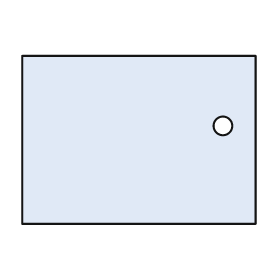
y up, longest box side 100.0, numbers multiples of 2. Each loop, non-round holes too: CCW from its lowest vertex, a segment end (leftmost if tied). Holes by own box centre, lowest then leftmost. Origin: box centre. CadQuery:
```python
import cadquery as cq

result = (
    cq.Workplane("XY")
    .moveTo(-50.0, -36.0)
    .lineTo(50.0, -36.0)
    .lineTo(50.0, 36.0)
    .lineTo(-50.0, 36.0)
    .close()
    .moveTo(36.0, 6.0)
    .circle(4.0)
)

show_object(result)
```